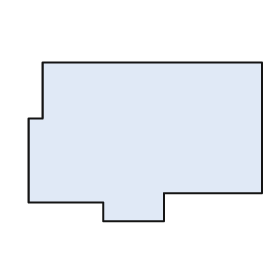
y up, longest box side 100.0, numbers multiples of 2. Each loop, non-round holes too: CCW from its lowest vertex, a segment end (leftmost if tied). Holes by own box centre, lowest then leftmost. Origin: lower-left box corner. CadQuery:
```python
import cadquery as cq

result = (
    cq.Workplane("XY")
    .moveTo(32.0, 0.0)
    .lineTo(58.0, 0.0)
    .lineTo(58.0, 12.0)
    .lineTo(100.0, 12.0)
    .lineTo(100.0, 68.0)
    .lineTo(6.0, 68.0)
    .lineTo(6.0, 44.0)
    .lineTo(0.0, 44.0)
    .lineTo(0.0, 8.0)
    .lineTo(32.0, 8.0)
    .close()
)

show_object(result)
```